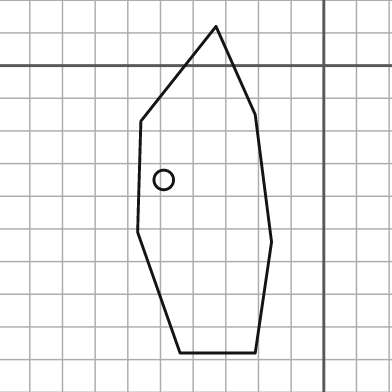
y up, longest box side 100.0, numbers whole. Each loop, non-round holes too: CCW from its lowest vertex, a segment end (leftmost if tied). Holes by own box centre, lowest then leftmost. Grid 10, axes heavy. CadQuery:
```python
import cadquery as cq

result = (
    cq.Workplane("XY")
    .moveTo(-44.0, -88.0)
    .lineTo(-21.0, -88.0)
    .lineTo(-16.0, -54.0)
    .lineTo(-21.0, -15.0)
    .lineTo(-33.0, 12.0)
    .lineTo(-56.0, -17.0)
    .lineTo(-57.0, -51.0)
    .close()
    .moveTo(-49.0, -35.0)
    .circle(3.0)
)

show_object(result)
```